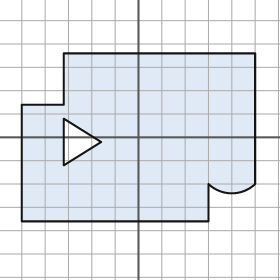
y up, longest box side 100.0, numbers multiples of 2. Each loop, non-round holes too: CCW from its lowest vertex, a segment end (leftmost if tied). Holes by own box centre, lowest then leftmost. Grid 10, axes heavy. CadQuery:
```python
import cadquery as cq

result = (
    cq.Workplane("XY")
    .moveTo(-50.0, -36.0)
    .lineTo(30.0, -36.0)
    .lineTo(30.0, -20.0)
    .threePointArc((40.0, -24.0), (50.0, -20.0))
    .lineTo(50.0, 36.0)
    .lineTo(-32.0, 36.0)
    .lineTo(-32.0, 14.0)
    .lineTo(-50.0, 14.0)
    .close()
    .moveTo(-32.0, -12.0)
    .lineTo(-16.0, -2.0)
    .lineTo(-32.0, 8.0)
    .close()
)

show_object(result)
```